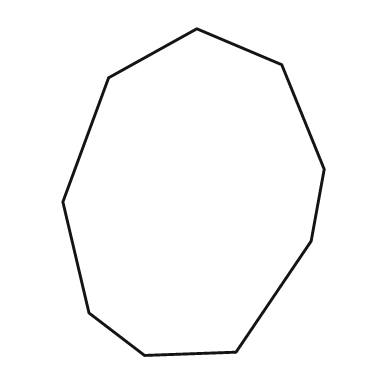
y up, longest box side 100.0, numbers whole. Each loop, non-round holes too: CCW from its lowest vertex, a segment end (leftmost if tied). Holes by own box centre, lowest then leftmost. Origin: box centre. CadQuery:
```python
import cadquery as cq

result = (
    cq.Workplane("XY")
    .moveTo(-15.0, -50.0)
    .lineTo(13.0, -49.0)
    .lineTo(36.0, -15.0)
    .lineTo(40.0, 7.0)
    .lineTo(27.0, 39.0)
    .lineTo(1.0, 50.0)
    .lineTo(-26.0, 35.0)
    .lineTo(-40.0, -3.0)
    .lineTo(-32.0, -37.0)
    .close()
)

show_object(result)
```